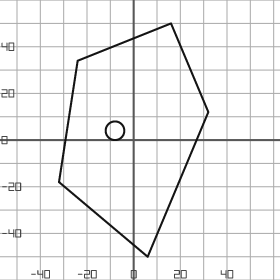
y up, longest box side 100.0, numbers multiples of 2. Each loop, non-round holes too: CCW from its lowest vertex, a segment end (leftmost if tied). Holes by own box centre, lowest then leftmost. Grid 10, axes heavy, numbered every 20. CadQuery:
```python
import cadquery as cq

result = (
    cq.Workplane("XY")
    .moveTo(6.0, -50.0)
    .lineTo(32.0, 12.0)
    .lineTo(16.0, 50.0)
    .lineTo(-24.0, 34.0)
    .lineTo(-32.0, -18.0)
    .close()
    .moveTo(-8.0, 4.0)
    .circle(4.0)
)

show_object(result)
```